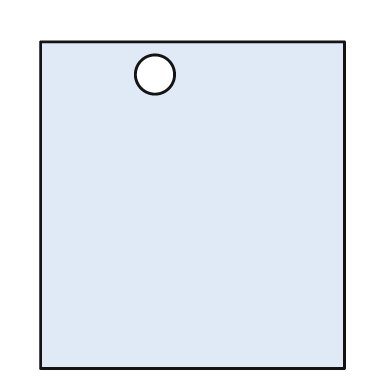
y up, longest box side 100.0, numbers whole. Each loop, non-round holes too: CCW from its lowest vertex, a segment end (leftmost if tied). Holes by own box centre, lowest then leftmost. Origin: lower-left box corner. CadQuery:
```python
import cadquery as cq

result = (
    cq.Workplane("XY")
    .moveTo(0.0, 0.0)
    .lineTo(93.0, 0.0)
    .lineTo(93.0, 100.0)
    .lineTo(0.0, 100.0)
    .close()
    .moveTo(35.0, 90.0)
    .circle(6.0)
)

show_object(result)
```